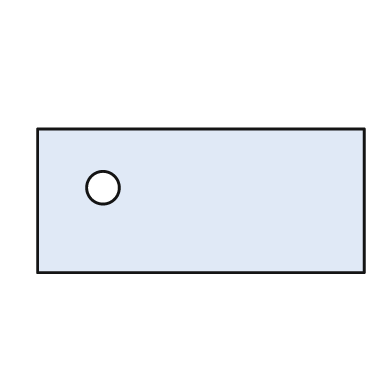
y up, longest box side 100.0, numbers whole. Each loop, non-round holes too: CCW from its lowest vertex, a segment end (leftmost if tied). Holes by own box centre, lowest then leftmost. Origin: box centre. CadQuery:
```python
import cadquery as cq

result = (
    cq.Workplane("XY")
    .moveTo(-50.0, -22.0)
    .lineTo(50.0, -22.0)
    .lineTo(50.0, 22.0)
    .lineTo(-50.0, 22.0)
    .close()
    .moveTo(-30.0, 4.0)
    .circle(5.0)
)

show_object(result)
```